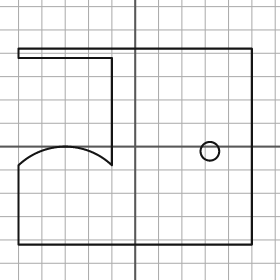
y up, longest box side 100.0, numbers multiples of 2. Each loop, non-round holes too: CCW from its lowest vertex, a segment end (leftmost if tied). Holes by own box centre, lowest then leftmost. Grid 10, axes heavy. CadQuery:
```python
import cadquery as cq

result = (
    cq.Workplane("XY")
    .moveTo(-50.0, -42.0)
    .lineTo(50.0, -42.0)
    .lineTo(50.0, 42.0)
    .lineTo(-50.0, 42.0)
    .lineTo(-50.0, 38.0)
    .lineTo(-10.0, 38.0)
    .lineTo(-10.0, -8.0)
    .threePointArc((-30.0, 0.0), (-50.0, -8.0))
    .close()
    .moveTo(32.0, -2.0)
    .circle(4.0)
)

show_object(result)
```